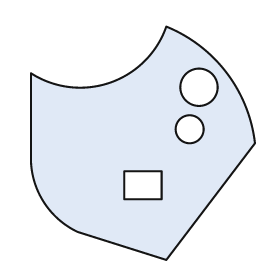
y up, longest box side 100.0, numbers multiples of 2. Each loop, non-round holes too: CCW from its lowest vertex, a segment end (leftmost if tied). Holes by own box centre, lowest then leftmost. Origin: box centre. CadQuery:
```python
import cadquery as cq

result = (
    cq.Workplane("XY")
    .moveTo(10.0, -50.0)
    .lineTo(48.0, 0.0)
    .threePointArc((36.0, 30.0), (10.0, 50.0))
    .threePointArc((-14.0, 26.0), (-48.0, 30.0))
    .lineTo(-48.0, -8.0)
    .threePointArc((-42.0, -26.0), (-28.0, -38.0))
    .close()
    .moveTo(-8.0, -24.0)
    .lineTo(8.0, -24.0)
    .lineTo(8.0, -12.0)
    .lineTo(-8.0, -12.0)
    .close()
    .moveTo(20.0, 6.0)
    .circle(6.0)
    .moveTo(24.0, 24.0)
    .circle(8.0)
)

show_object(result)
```